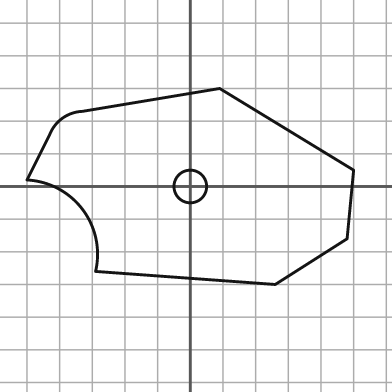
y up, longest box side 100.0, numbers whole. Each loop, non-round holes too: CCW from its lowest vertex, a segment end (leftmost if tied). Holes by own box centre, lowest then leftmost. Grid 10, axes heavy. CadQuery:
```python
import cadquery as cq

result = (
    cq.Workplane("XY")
    .moveTo(26.0, -30.0)
    .lineTo(48.0, -16.0)
    .lineTo(50.0, 5.0)
    .lineTo(9.0, 30.0)
    .lineTo(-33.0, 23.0)
    .threePointArc((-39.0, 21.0), (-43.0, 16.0))
    .lineTo(-50.0, 2.0)
    .threePointArc((-33.0, -7.0), (-29.0, -26.0))
    .close()
    .moveTo(0.0, 0.0)
    .circle(5.0)
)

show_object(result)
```